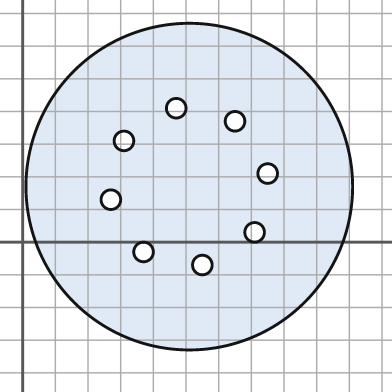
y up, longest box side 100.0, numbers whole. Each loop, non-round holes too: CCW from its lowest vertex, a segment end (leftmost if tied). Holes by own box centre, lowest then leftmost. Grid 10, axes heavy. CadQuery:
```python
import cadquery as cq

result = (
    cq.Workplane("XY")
    .moveTo(51.0, 17.0)
    .circle(50.0)
    .moveTo(55.0, -7.0)
    .circle(3.0)
    .moveTo(37.0, -3.0)
    .circle(3.0)
    .moveTo(71.0, 3.0)
    .circle(3.0)
    .moveTo(27.0, 13.0)
    .circle(3.0)
    .moveTo(75.0, 21.0)
    .circle(3.0)
    .moveTo(31.0, 31.0)
    .circle(3.0)
    .moveTo(65.0, 37.0)
    .circle(3.0)
    .moveTo(47.0, 41.0)
    .circle(3.0)
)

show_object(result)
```